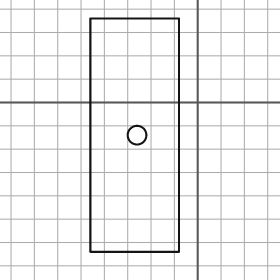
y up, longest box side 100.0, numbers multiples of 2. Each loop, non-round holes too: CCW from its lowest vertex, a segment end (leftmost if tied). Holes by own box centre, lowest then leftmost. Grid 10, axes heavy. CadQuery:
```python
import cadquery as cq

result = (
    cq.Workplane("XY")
    .moveTo(-46.0, -64.0)
    .lineTo(-8.0, -64.0)
    .lineTo(-8.0, 36.0)
    .lineTo(-46.0, 36.0)
    .close()
    .moveTo(-26.0, -14.0)
    .circle(4.0)
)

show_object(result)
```